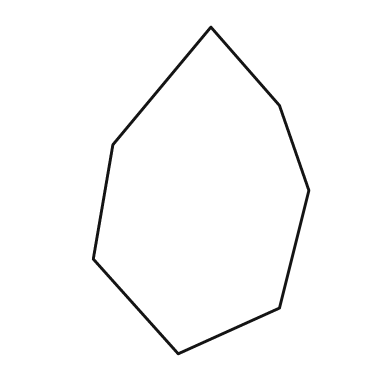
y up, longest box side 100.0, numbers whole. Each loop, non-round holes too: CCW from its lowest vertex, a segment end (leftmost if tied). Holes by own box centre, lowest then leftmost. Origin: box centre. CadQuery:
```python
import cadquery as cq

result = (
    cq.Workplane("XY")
    .moveTo(-7.0, -50.0)
    .lineTo(24.0, -36.0)
    .lineTo(33.0, 0.0)
    .lineTo(24.0, 26.0)
    .lineTo(3.0, 50.0)
    .lineTo(-27.0, 14.0)
    .lineTo(-33.0, -21.0)
    .close()
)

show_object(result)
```